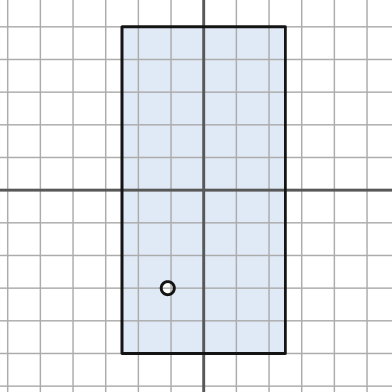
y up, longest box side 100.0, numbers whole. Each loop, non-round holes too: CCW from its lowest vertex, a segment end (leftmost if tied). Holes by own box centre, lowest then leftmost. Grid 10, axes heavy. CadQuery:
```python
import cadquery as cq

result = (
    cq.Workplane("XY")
    .moveTo(-25.0, -50.0)
    .lineTo(25.0, -50.0)
    .lineTo(25.0, 50.0)
    .lineTo(-25.0, 50.0)
    .close()
    .moveTo(-11.0, -30.0)
    .circle(2.0)
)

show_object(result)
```